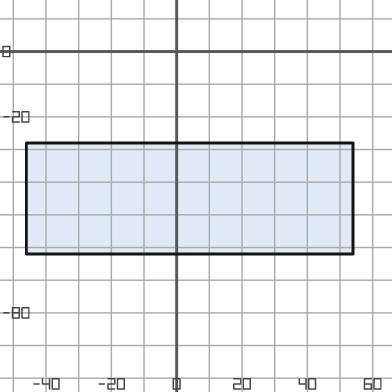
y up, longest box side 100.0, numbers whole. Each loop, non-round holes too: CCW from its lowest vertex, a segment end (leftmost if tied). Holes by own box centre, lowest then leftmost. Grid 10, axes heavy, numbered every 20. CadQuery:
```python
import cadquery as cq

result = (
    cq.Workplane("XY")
    .moveTo(-46.0, -62.0)
    .lineTo(54.0, -62.0)
    .lineTo(54.0, -28.0)
    .lineTo(-46.0, -28.0)
    .close()
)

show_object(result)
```